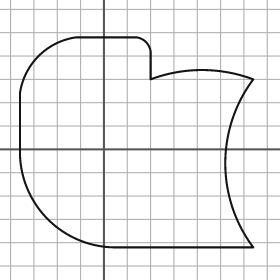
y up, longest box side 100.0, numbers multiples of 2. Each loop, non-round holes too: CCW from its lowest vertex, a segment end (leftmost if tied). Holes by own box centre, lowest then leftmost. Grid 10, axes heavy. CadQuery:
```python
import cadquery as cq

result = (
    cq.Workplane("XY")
    .moveTo(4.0, -42.0)
    .lineTo(64.0, -42.0)
    .threePointArc((52.0, -6.0), (64.0, 30.0))
    .threePointArc((42.0, 34.0), (20.0, 30.0))
    .lineTo(20.0, 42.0)
    .threePointArc((18.0, 46.0), (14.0, 48.0))
    .lineTo(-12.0, 48.0)
    .threePointArc((-28.0, 40.0), (-36.0, 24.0))
    .lineTo(-36.0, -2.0)
    .threePointArc((-24.0, -30.0), (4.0, -42.0))
    .close()
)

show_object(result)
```